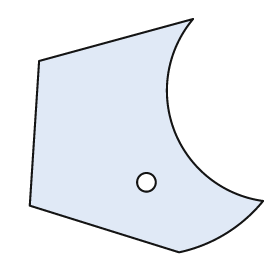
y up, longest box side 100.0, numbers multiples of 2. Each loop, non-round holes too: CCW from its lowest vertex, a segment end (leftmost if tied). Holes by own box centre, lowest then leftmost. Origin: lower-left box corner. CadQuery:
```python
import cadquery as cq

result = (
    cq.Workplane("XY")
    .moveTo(64.0, 0.0)
    .threePointArc((84.0, 8.0), (100.0, 22.0))
    .threePointArc((62.0, 52.0), (70.0, 100.0))
    .lineTo(4.0, 82.0)
    .lineTo(0.0, 20.0)
    .close()
    .moveTo(50.0, 30.0)
    .circle(4.0)
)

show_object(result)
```